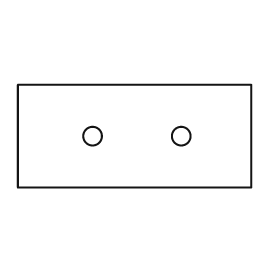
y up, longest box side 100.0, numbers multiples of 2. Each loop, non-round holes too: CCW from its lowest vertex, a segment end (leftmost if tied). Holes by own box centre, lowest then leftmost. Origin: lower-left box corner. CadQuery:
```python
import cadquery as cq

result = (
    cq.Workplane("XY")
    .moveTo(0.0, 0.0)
    .lineTo(100.0, 0.0)
    .lineTo(100.0, 44.0)
    .lineTo(0.0, 44.0)
    .close()
    .moveTo(32.0, 22.0)
    .circle(4.0)
    .moveTo(70.0, 22.0)
    .circle(4.0)
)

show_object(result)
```